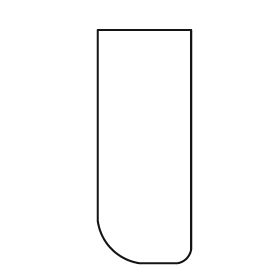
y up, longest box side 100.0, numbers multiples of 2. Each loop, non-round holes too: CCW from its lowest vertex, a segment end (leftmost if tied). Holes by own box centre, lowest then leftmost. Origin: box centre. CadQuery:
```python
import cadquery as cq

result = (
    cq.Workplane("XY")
    .moveTo(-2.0, -50.0)
    .lineTo(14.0, -50.0)
    .threePointArc((18.0, -48.0), (20.0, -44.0))
    .lineTo(20.0, 50.0)
    .lineTo(-20.0, 50.0)
    .lineTo(-20.0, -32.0)
    .threePointArc((-14.0, -44.0), (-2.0, -50.0))
    .close()
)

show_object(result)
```